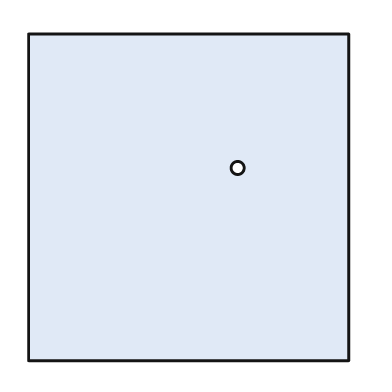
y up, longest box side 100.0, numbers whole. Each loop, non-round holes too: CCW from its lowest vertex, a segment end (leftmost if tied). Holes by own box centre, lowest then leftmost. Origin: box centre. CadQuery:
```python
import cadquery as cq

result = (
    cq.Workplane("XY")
    .moveTo(-49.0, -50.0)
    .lineTo(49.0, -50.0)
    .lineTo(49.0, 50.0)
    .lineTo(-49.0, 50.0)
    .close()
    .moveTo(15.0, 9.0)
    .circle(2.0)
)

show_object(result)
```